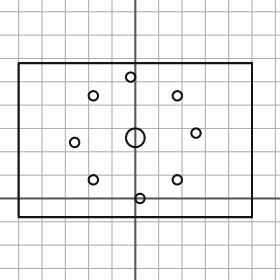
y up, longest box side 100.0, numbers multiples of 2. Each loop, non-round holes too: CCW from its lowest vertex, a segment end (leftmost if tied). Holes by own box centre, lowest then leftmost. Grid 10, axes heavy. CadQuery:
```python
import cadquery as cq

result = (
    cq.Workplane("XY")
    .moveTo(-50.0, -8.0)
    .lineTo(50.0, -8.0)
    .lineTo(50.0, 58.0)
    .lineTo(-50.0, 58.0)
    .close()
    .moveTo(2.0, 0.0)
    .circle(2.0)
    .moveTo(-18.0, 8.0)
    .circle(2.0)
    .moveTo(18.0, 8.0)
    .circle(2.0)
    .moveTo(-26.0, 24.0)
    .circle(2.0)
    .moveTo(0.0, 26.0)
    .circle(4.0)
    .moveTo(26.0, 28.0)
    .circle(2.0)
    .moveTo(-18.0, 44.0)
    .circle(2.0)
    .moveTo(18.0, 44.0)
    .circle(2.0)
    .moveTo(-2.0, 52.0)
    .circle(2.0)
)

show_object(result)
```